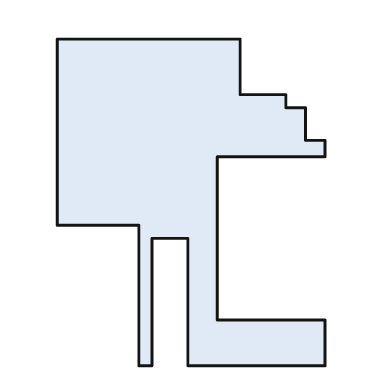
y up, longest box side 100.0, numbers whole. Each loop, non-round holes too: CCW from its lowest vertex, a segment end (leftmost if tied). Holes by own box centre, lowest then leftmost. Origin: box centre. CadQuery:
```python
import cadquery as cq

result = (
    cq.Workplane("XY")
    .moveTo(-16.0, -50.0)
    .lineTo(-12.0, -50.0)
    .lineTo(-12.0, -11.0)
    .lineTo(-1.0, -11.0)
    .lineTo(-1.0, -50.0)
    .lineTo(41.0, -50.0)
    .lineTo(41.0, -36.0)
    .lineTo(8.0, -36.0)
    .lineTo(8.0, 14.0)
    .lineTo(41.0, 14.0)
    .lineTo(41.0, 19.0)
    .lineTo(35.0, 19.0)
    .lineTo(35.0, 29.0)
    .lineTo(29.0, 29.0)
    .lineTo(29.0, 33.0)
    .lineTo(15.0, 33.0)
    .lineTo(15.0, 50.0)
    .lineTo(-41.0, 50.0)
    .lineTo(-41.0, -7.0)
    .lineTo(-16.0, -7.0)
    .close()
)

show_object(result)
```